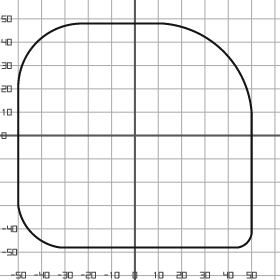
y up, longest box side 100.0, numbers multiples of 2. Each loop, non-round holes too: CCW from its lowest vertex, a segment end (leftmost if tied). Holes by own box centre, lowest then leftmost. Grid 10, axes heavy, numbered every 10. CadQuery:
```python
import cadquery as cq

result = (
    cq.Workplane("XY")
    .moveTo(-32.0, -48.0)
    .lineTo(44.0, -48.0)
    .threePointArc((48.0, -46.0), (50.0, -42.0))
    .lineTo(50.0, 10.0)
    .threePointArc((38.0, 36.0), (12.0, 48.0))
    .lineTo(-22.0, 48.0)
    .threePointArc((-42.0, 40.0), (-50.0, 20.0))
    .lineTo(-50.0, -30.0)
    .threePointArc((-44.0, -42.0), (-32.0, -48.0))
    .close()
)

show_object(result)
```